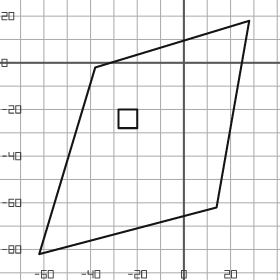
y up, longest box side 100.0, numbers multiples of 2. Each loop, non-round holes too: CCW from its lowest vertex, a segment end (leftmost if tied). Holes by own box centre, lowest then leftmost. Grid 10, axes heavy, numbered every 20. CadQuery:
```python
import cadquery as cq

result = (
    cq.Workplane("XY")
    .moveTo(-62.0, -82.0)
    .lineTo(14.0, -62.0)
    .lineTo(28.0, 18.0)
    .lineTo(-38.0, -2.0)
    .close()
    .moveTo(-28.0, -28.0)
    .lineTo(-20.0, -28.0)
    .lineTo(-20.0, -20.0)
    .lineTo(-28.0, -20.0)
    .close()
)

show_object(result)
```